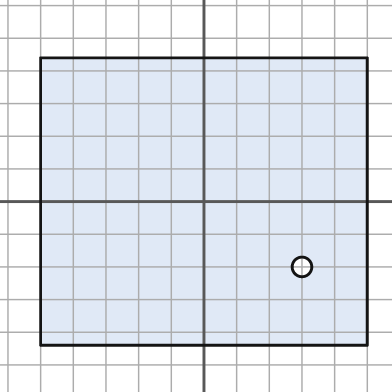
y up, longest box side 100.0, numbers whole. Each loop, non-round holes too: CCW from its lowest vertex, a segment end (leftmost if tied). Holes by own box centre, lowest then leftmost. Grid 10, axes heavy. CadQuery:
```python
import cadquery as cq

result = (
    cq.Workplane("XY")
    .moveTo(-50.0, -44.0)
    .lineTo(50.0, -44.0)
    .lineTo(50.0, 44.0)
    .lineTo(-50.0, 44.0)
    .close()
    .moveTo(30.0, -20.0)
    .circle(3.0)
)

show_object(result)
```